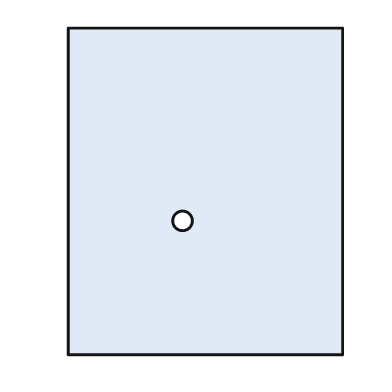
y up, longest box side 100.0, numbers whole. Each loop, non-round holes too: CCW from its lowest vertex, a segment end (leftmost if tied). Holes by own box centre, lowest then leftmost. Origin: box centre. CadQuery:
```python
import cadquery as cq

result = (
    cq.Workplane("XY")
    .moveTo(-42.0, -50.0)
    .lineTo(42.0, -50.0)
    .lineTo(42.0, 50.0)
    .lineTo(-42.0, 50.0)
    .close()
    .moveTo(-7.0, -9.0)
    .circle(3.0)
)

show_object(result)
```